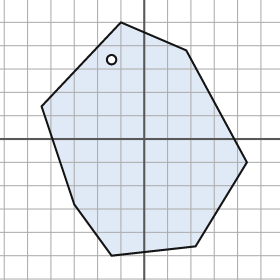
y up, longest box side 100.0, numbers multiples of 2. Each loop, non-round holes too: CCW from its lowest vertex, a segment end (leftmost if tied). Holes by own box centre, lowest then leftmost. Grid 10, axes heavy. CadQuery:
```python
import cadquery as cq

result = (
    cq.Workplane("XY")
    .moveTo(-14.0, -50.0)
    .lineTo(22.0, -46.0)
    .lineTo(44.0, -10.0)
    .lineTo(18.0, 38.0)
    .lineTo(-10.0, 50.0)
    .lineTo(-44.0, 14.0)
    .lineTo(-30.0, -28.0)
    .close()
    .moveTo(-14.0, 34.0)
    .circle(2.0)
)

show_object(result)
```